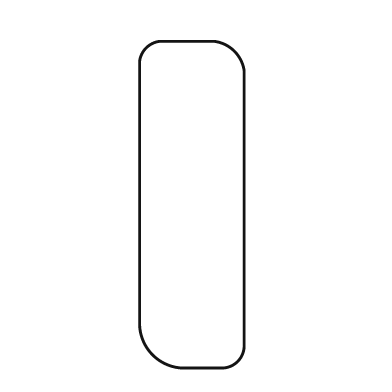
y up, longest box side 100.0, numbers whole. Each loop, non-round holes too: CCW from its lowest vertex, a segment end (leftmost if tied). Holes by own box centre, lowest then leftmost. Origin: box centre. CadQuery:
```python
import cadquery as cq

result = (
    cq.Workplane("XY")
    .moveTo(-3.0, -50.0)
    .lineTo(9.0, -50.0)
    .threePointArc((14.0, -48.0), (16.0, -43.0))
    .lineTo(16.0, 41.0)
    .threePointArc((13.0, 47.0), (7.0, 50.0))
    .lineTo(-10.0, 50.0)
    .threePointArc((-14.0, 48.0), (-16.0, 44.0))
    .lineTo(-16.0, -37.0)
    .threePointArc((-12.0, -46.0), (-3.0, -50.0))
    .close()
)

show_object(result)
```